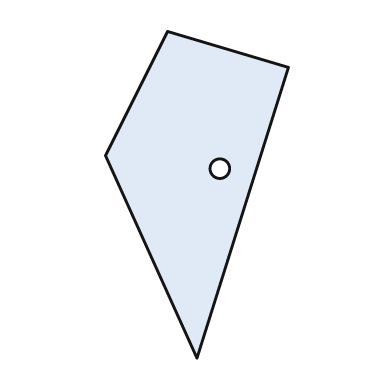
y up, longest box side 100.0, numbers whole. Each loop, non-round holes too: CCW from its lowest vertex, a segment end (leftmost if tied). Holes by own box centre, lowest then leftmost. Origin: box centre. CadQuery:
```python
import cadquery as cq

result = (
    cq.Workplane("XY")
    .moveTo(0.0, -50.0)
    .lineTo(28.0, 39.0)
    .lineTo(-9.0, 50.0)
    .lineTo(-28.0, 12.0)
    .close()
    .moveTo(7.0, 8.0)
    .circle(3.0)
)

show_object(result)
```